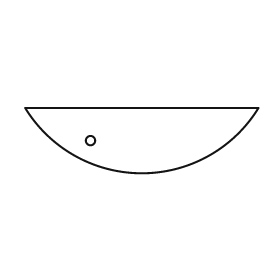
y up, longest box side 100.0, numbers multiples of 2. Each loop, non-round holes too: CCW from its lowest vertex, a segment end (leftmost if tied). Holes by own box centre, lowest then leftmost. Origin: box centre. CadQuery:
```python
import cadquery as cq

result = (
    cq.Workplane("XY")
    .moveTo(-50.0, 14.0)
    .threePointArc((0.0, -14.0), (50.0, 14.0))
    .close()
    .moveTo(-22.0, 0.0)
    .circle(2.0)
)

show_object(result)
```